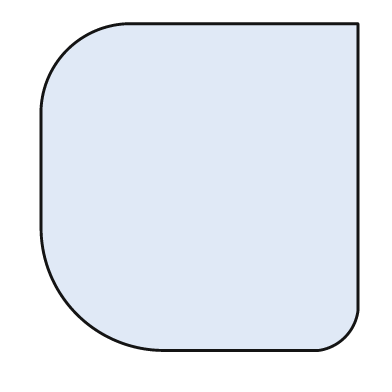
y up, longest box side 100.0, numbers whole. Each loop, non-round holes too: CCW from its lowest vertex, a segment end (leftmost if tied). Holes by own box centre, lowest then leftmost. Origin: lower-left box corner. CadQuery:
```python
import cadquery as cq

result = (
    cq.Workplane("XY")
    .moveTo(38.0, 0.0)
    .lineTo(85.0, 0.0)
    .threePointArc((93.0, 4.0), (97.0, 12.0))
    .lineTo(97.0, 100.0)
    .lineTo(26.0, 100.0)
    .threePointArc((8.0, 92.0), (0.0, 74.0))
    .lineTo(0.0, 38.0)
    .threePointArc((11.0, 11.0), (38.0, 0.0))
    .close()
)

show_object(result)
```